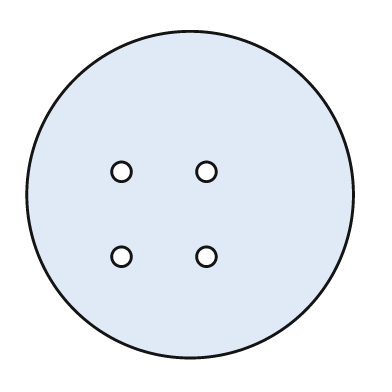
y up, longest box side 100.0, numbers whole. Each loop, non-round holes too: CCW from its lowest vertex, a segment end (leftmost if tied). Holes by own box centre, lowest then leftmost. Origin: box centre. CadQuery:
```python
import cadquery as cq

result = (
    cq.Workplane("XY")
    .moveTo(0.0, 0.0)
    .circle(50.0)
    .moveTo(-21.0, -19.0)
    .circle(3.0)
    .moveTo(5.0, -19.0)
    .circle(3.0)
    .moveTo(-21.0, 7.0)
    .circle(3.0)
    .moveTo(5.0, 7.0)
    .circle(3.0)
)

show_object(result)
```